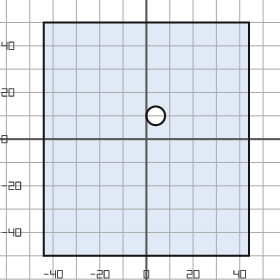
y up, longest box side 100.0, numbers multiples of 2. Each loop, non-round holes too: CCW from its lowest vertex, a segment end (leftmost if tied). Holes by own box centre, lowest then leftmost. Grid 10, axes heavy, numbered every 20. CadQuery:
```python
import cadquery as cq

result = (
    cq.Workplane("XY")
    .moveTo(-44.0, -50.0)
    .lineTo(44.0, -50.0)
    .lineTo(44.0, 50.0)
    .lineTo(-44.0, 50.0)
    .close()
    .moveTo(4.0, 10.0)
    .circle(4.0)
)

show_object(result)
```